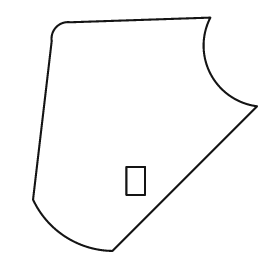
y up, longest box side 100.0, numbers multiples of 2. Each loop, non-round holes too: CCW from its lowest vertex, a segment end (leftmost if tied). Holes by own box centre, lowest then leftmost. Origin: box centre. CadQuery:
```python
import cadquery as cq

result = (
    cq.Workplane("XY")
    .moveTo(-14.0, -50.0)
    .lineTo(48.0, 12.0)
    .threePointArc((28.0, 26.0), (28.0, 50.0))
    .lineTo(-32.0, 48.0)
    .threePointArc((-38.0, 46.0), (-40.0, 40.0))
    .lineTo(-48.0, -28.0)
    .threePointArc((-34.0, -44.0), (-14.0, -50.0))
    .close()
    .moveTo(-8.0, -26.0)
    .lineTo(0.0, -26.0)
    .lineTo(0.0, -14.0)
    .lineTo(-8.0, -14.0)
    .close()
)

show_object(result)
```